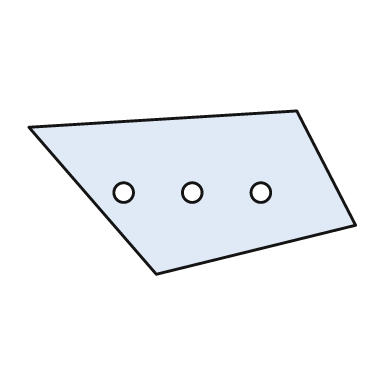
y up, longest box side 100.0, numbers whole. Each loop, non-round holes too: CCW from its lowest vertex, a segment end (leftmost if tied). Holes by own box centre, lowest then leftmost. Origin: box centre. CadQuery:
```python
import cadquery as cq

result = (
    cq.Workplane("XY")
    .moveTo(-11.0, -25.0)
    .lineTo(50.0, -10.0)
    .lineTo(32.0, 25.0)
    .lineTo(-50.0, 20.0)
    .close()
    .moveTo(-21.0, 0.0)
    .circle(3.0)
    .moveTo(0.0, 0.0)
    .circle(3.0)
    .moveTo(21.0, 0.0)
    .circle(3.0)
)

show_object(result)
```